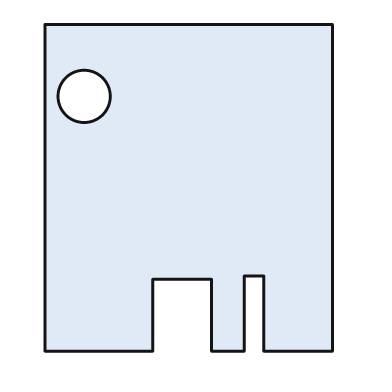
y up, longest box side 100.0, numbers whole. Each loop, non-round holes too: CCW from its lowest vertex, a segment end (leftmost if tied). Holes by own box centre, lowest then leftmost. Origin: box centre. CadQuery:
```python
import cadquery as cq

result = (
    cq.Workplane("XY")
    .moveTo(-44.0, -50.0)
    .lineTo(-11.0, -50.0)
    .lineTo(-11.0, -28.0)
    .lineTo(7.0, -28.0)
    .lineTo(7.0, -50.0)
    .lineTo(17.0, -50.0)
    .lineTo(17.0, -27.0)
    .lineTo(23.0, -27.0)
    .lineTo(23.0, -50.0)
    .lineTo(44.0, -50.0)
    .lineTo(44.0, 50.0)
    .lineTo(-44.0, 50.0)
    .close()
    .moveTo(-32.0, 28.0)
    .circle(8.0)
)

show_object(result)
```